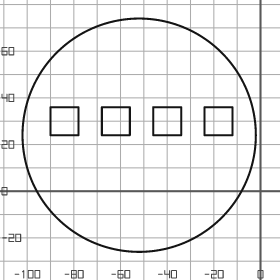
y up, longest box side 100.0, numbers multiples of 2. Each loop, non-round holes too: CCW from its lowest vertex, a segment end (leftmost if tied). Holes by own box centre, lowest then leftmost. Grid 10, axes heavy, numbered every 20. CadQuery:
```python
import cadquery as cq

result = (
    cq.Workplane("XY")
    .moveTo(-52.0, 24.0)
    .circle(50.0)
    .moveTo(-90.0, 24.0)
    .lineTo(-78.0, 24.0)
    .lineTo(-78.0, 36.0)
    .lineTo(-90.0, 36.0)
    .close()
    .moveTo(-68.0, 24.0)
    .lineTo(-56.0, 24.0)
    .lineTo(-56.0, 36.0)
    .lineTo(-68.0, 36.0)
    .close()
    .moveTo(-46.0, 24.0)
    .lineTo(-34.0, 24.0)
    .lineTo(-34.0, 36.0)
    .lineTo(-46.0, 36.0)
    .close()
    .moveTo(-24.0, 24.0)
    .lineTo(-12.0, 24.0)
    .lineTo(-12.0, 36.0)
    .lineTo(-24.0, 36.0)
    .close()
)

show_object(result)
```